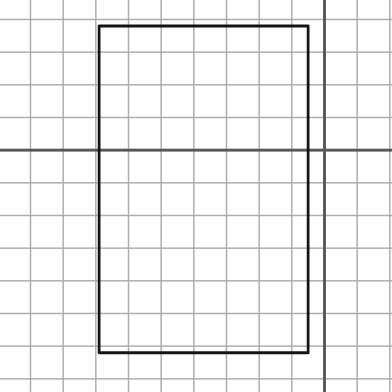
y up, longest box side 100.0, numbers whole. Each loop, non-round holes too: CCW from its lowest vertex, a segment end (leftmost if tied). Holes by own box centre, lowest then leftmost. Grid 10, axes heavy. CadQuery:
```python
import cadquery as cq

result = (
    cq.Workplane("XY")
    .moveTo(-69.0, -62.0)
    .lineTo(-5.0, -62.0)
    .lineTo(-5.0, 38.0)
    .lineTo(-69.0, 38.0)
    .close()
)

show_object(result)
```